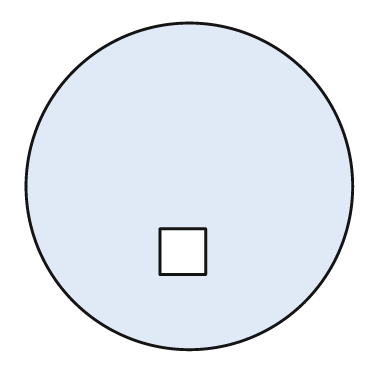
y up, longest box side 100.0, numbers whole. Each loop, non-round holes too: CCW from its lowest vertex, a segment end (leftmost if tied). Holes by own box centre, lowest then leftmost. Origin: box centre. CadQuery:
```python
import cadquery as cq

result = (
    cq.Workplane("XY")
    .moveTo(0.0, 0.0)
    .circle(50.0)
    .moveTo(-9.0, -27.0)
    .lineTo(5.0, -27.0)
    .lineTo(5.0, -13.0)
    .lineTo(-9.0, -13.0)
    .close()
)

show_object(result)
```